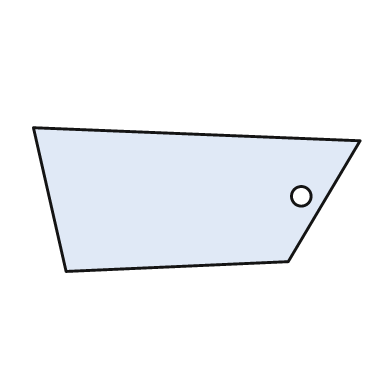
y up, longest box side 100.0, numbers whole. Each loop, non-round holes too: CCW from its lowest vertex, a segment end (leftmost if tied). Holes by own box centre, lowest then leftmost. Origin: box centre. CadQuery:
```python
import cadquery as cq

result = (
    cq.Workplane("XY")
    .moveTo(-40.0, -22.0)
    .lineTo(28.0, -19.0)
    .lineTo(50.0, 18.0)
    .lineTo(-50.0, 22.0)
    .close()
    .moveTo(32.0, 1.0)
    .circle(3.0)
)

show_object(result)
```